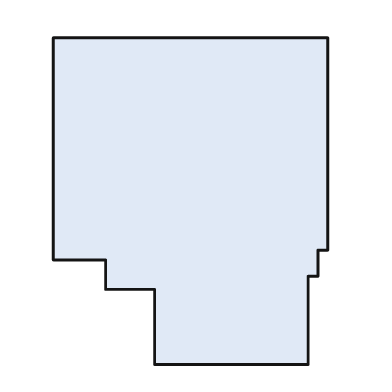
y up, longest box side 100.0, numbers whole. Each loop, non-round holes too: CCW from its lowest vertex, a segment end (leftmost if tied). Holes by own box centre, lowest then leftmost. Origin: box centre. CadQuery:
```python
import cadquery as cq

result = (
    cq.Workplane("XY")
    .moveTo(-11.0, -50.0)
    .lineTo(36.0, -50.0)
    .lineTo(36.0, -23.0)
    .lineTo(39.0, -23.0)
    .lineTo(39.0, -15.0)
    .lineTo(42.0, -15.0)
    .lineTo(42.0, 50.0)
    .lineTo(-42.0, 50.0)
    .lineTo(-42.0, -18.0)
    .lineTo(-26.0, -18.0)
    .lineTo(-26.0, -27.0)
    .lineTo(-11.0, -27.0)
    .close()
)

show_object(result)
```